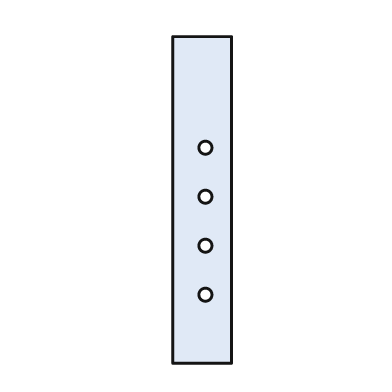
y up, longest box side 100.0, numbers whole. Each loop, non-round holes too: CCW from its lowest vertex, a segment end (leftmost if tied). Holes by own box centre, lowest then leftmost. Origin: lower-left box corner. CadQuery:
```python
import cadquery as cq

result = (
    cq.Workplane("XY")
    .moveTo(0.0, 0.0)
    .lineTo(18.0, 0.0)
    .lineTo(18.0, 100.0)
    .lineTo(0.0, 100.0)
    .close()
    .moveTo(10.0, 21.0)
    .circle(2.0)
    .moveTo(10.0, 36.0)
    .circle(2.0)
    .moveTo(10.0, 51.0)
    .circle(2.0)
    .moveTo(10.0, 66.0)
    .circle(2.0)
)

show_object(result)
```